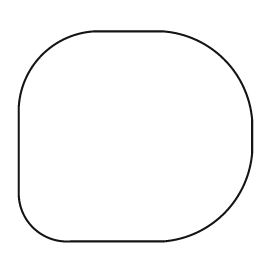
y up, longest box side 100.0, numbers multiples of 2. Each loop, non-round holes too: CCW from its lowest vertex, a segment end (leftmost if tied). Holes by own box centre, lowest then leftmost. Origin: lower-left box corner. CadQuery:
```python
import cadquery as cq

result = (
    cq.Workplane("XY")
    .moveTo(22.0, 0.0)
    .lineTo(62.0, 0.0)
    .threePointArc((88.0, 12.0), (100.0, 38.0))
    .lineTo(100.0, 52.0)
    .threePointArc((88.0, 78.0), (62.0, 90.0))
    .lineTo(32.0, 90.0)
    .threePointArc((10.0, 80.0), (0.0, 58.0))
    .lineTo(0.0, 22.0)
    .threePointArc((6.0, 6.0), (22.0, 0.0))
    .close()
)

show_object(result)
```